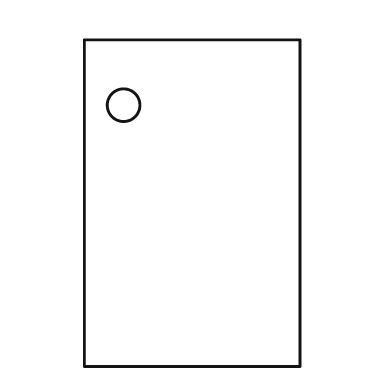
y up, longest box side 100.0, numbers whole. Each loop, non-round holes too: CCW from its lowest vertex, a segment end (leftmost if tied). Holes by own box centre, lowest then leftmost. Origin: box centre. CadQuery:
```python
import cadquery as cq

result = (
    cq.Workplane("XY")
    .moveTo(-33.0, -50.0)
    .lineTo(33.0, -50.0)
    .lineTo(33.0, 50.0)
    .lineTo(-33.0, 50.0)
    .close()
    .moveTo(-21.0, 30.0)
    .circle(5.0)
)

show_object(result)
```